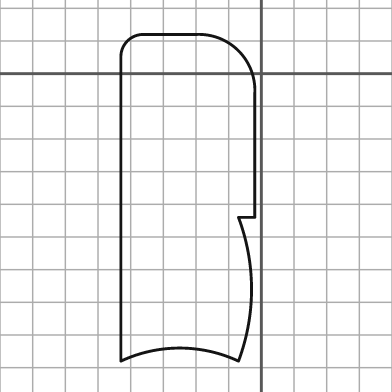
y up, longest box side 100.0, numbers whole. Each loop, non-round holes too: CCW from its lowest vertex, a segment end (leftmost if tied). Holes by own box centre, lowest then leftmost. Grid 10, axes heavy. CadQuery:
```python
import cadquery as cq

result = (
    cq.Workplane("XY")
    .moveTo(-43.0, -88.0)
    .threePointArc((-25.0, -84.0), (-7.0, -88.0))
    .threePointArc((-3.0, -66.0), (-7.0, -44.0))
    .lineTo(-2.0, -44.0)
    .lineTo(-2.0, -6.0)
    .threePointArc((-7.0, 7.0), (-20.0, 12.0))
    .lineTo(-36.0, 12.0)
    .threePointArc((-41.0, 10.0), (-43.0, 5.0))
    .close()
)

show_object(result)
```